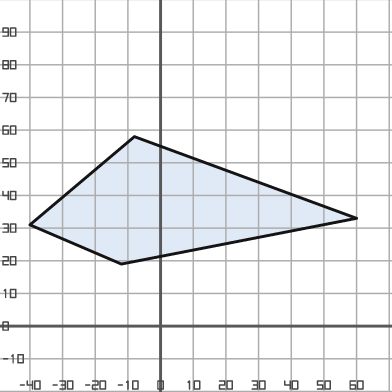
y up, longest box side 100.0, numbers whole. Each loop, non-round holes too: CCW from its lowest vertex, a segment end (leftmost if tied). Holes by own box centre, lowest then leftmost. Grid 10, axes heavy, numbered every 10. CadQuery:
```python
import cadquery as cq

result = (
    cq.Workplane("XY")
    .moveTo(-12.0, 19.0)
    .lineTo(60.0, 33.0)
    .lineTo(-8.0, 58.0)
    .lineTo(-40.0, 31.0)
    .close()
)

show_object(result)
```